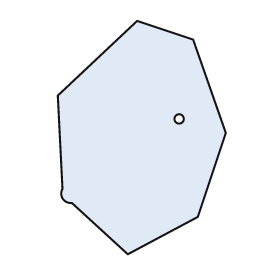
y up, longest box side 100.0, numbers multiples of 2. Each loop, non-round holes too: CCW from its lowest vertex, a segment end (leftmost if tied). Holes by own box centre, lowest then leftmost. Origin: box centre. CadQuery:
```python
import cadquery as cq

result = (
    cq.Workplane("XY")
    .moveTo(-6.0, -50.0)
    .lineTo(24.0, -34.0)
    .lineTo(36.0, 2.0)
    .lineTo(22.0, 42.0)
    .lineTo(-2.0, 50.0)
    .lineTo(-36.0, 18.0)
    .lineTo(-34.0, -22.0)
    .threePointArc((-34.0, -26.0), (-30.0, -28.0))
    .close()
    .moveTo(16.0, 8.0)
    .circle(2.0)
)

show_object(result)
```